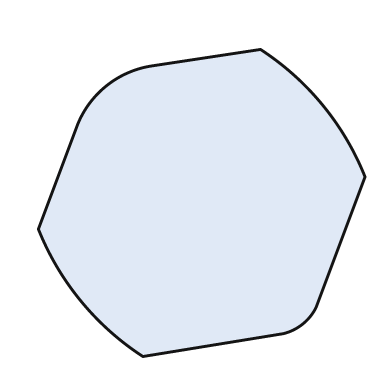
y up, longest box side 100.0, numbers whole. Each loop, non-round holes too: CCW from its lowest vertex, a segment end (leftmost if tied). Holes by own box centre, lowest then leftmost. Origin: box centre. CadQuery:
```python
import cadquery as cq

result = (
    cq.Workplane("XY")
    .moveTo(-18.0, -47.0)
    .lineTo(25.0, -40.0)
    .threePointArc((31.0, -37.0), (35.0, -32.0))
    .lineTo(50.0, 8.0)
    .threePointArc((37.0, 30.0), (18.0, 47.0))
    .lineTo(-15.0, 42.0)
    .threePointArc((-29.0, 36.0), (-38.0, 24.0))
    .lineTo(-50.0, -8.0)
    .threePointArc((-37.0, -30.0), (-18.0, -47.0))
    .close()
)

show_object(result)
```